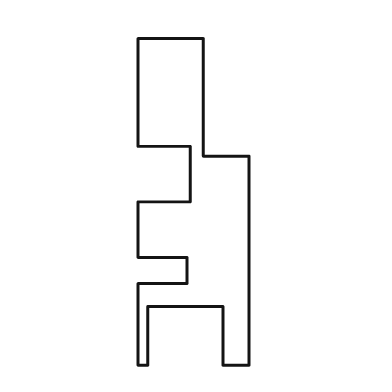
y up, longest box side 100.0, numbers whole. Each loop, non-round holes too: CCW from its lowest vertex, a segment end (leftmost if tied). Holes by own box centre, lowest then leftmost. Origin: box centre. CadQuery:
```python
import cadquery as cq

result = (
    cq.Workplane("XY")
    .moveTo(-17.0, -50.0)
    .lineTo(-14.0, -50.0)
    .lineTo(-14.0, -32.0)
    .lineTo(9.0, -32.0)
    .lineTo(9.0, -50.0)
    .lineTo(17.0, -50.0)
    .lineTo(17.0, 14.0)
    .lineTo(3.0, 14.0)
    .lineTo(3.0, 50.0)
    .lineTo(-17.0, 50.0)
    .lineTo(-17.0, 17.0)
    .lineTo(-1.0, 17.0)
    .lineTo(-1.0, 0.0)
    .lineTo(-17.0, 0.0)
    .lineTo(-17.0, -17.0)
    .lineTo(-2.0, -17.0)
    .lineTo(-2.0, -25.0)
    .lineTo(-17.0, -25.0)
    .close()
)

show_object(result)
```